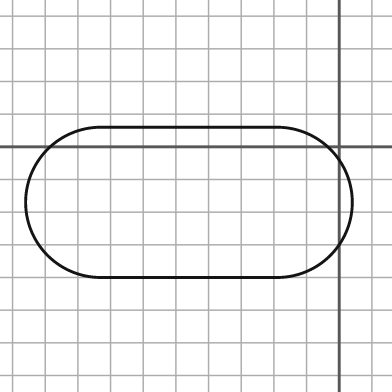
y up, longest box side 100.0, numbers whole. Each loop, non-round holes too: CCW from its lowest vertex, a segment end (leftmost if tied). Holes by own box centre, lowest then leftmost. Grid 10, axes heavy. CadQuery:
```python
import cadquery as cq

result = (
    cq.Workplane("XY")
    .moveTo(-73.0, -40.0)
    .lineTo(-19.0, -40.0)
    .threePointArc((4.0, -17.0), (-19.0, 6.0))
    .lineTo(-73.0, 6.0)
    .threePointArc((-96.0, -17.0), (-73.0, -40.0))
    .close()
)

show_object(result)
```